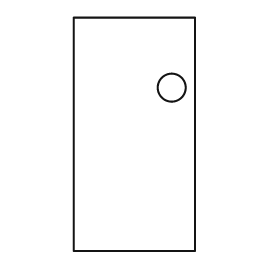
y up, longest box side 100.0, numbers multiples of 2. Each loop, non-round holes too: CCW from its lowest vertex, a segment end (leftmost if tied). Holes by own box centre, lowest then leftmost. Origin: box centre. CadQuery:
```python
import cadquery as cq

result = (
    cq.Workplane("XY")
    .moveTo(-26.0, -50.0)
    .lineTo(26.0, -50.0)
    .lineTo(26.0, 50.0)
    .lineTo(-26.0, 50.0)
    .close()
    .moveTo(16.0, 20.0)
    .circle(6.0)
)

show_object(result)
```